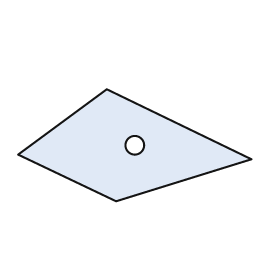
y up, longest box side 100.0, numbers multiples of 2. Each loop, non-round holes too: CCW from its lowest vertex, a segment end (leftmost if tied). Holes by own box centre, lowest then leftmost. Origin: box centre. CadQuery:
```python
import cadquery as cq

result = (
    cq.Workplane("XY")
    .moveTo(-8.0, -24.0)
    .lineTo(50.0, -6.0)
    .lineTo(-12.0, 24.0)
    .lineTo(-50.0, -4.0)
    .close()
    .moveTo(0.0, 0.0)
    .circle(4.0)
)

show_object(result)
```